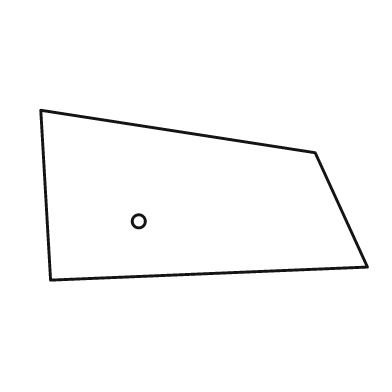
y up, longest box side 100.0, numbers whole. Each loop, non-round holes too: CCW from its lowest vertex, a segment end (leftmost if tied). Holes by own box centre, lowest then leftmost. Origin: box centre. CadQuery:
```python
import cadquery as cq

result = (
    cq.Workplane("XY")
    .moveTo(-47.0, -26.0)
    .lineTo(50.0, -22.0)
    .lineTo(34.0, 13.0)
    .lineTo(-50.0, 26.0)
    .close()
    .moveTo(-20.0, -8.0)
    .circle(2.0)
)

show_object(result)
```